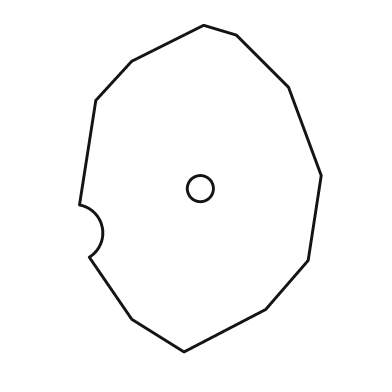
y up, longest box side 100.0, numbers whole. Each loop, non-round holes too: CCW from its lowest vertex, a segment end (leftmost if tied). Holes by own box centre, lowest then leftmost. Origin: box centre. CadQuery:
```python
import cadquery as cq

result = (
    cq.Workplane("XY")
    .moveTo(-5.0, -50.0)
    .lineTo(20.0, -37.0)
    .lineTo(33.0, -22.0)
    .lineTo(37.0, 4.0)
    .lineTo(27.0, 31.0)
    .lineTo(11.0, 47.0)
    .lineTo(1.0, 50.0)
    .lineTo(-21.0, 39.0)
    .lineTo(-32.0, 27.0)
    .lineTo(-37.0, -5.0)
    .threePointArc((-30.0, -12.0), (-34.0, -21.0))
    .lineTo(-21.0, -40.0)
    .close()
    .moveTo(0.0, 0.0)
    .circle(4.0)
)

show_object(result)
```